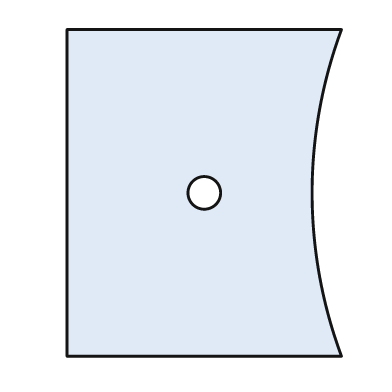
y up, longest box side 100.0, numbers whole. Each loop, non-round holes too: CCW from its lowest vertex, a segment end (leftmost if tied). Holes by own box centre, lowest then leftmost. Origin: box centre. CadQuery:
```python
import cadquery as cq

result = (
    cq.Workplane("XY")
    .moveTo(-42.0, -50.0)
    .lineTo(42.0, -50.0)
    .threePointArc((33.0, 0.0), (42.0, 50.0))
    .lineTo(-42.0, 50.0)
    .close()
    .moveTo(0.0, 0.0)
    .circle(5.0)
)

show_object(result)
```